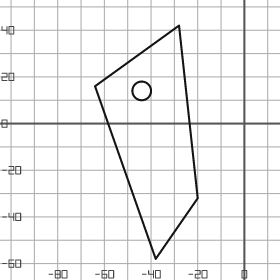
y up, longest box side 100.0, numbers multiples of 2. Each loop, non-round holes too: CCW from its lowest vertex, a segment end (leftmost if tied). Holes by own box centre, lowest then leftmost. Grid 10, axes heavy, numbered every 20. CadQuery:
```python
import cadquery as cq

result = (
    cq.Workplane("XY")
    .moveTo(-38.0, -58.0)
    .lineTo(-20.0, -32.0)
    .lineTo(-28.0, 42.0)
    .lineTo(-64.0, 16.0)
    .close()
    .moveTo(-44.0, 14.0)
    .circle(4.0)
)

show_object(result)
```